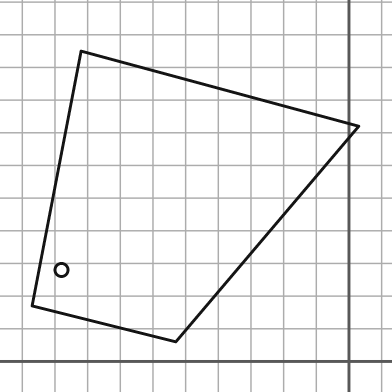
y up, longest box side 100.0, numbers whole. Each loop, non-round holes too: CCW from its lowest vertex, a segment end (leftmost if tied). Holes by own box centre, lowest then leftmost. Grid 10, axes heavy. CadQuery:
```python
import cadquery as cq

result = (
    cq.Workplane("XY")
    .moveTo(-53.0, 6.0)
    .lineTo(3.0, 72.0)
    .lineTo(-82.0, 95.0)
    .lineTo(-97.0, 17.0)
    .close()
    .moveTo(-88.0, 28.0)
    .circle(2.0)
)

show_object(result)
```